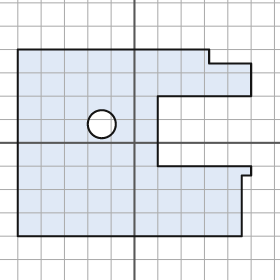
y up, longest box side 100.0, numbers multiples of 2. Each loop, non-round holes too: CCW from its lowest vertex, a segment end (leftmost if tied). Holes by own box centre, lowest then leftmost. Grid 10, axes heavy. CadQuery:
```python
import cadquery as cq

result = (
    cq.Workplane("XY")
    .moveTo(-50.0, -40.0)
    .lineTo(46.0, -40.0)
    .lineTo(46.0, -14.0)
    .lineTo(50.0, -14.0)
    .lineTo(50.0, -10.0)
    .lineTo(10.0, -10.0)
    .lineTo(10.0, 20.0)
    .lineTo(50.0, 20.0)
    .lineTo(50.0, 34.0)
    .lineTo(32.0, 34.0)
    .lineTo(32.0, 40.0)
    .lineTo(-50.0, 40.0)
    .close()
    .moveTo(-14.0, 8.0)
    .circle(6.0)
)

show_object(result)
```